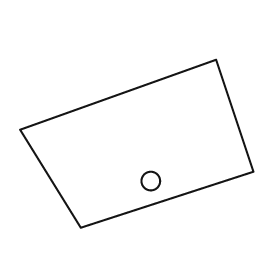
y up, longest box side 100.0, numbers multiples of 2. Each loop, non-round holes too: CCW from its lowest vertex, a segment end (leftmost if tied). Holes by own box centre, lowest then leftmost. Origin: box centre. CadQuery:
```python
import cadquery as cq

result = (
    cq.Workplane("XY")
    .moveTo(-24.0, -36.0)
    .lineTo(50.0, -12.0)
    .lineTo(34.0, 36.0)
    .lineTo(-50.0, 6.0)
    .close()
    .moveTo(6.0, -16.0)
    .circle(4.0)
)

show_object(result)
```